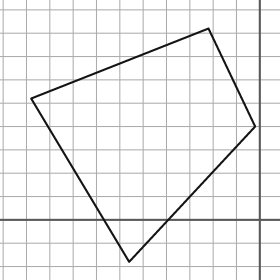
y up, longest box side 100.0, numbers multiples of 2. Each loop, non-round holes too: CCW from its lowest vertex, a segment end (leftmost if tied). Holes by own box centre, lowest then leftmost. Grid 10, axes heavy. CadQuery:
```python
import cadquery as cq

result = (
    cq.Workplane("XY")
    .moveTo(-56.0, -18.0)
    .lineTo(-2.0, 40.0)
    .lineTo(-22.0, 82.0)
    .lineTo(-98.0, 52.0)
    .close()
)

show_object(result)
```